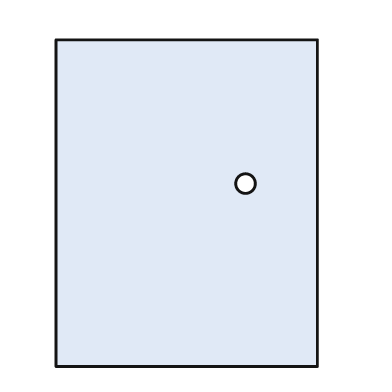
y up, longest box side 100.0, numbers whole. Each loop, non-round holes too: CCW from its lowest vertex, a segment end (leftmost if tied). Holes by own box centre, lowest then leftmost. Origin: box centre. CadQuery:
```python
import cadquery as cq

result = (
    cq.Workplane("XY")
    .moveTo(-40.0, -50.0)
    .lineTo(40.0, -50.0)
    .lineTo(40.0, 50.0)
    .lineTo(-40.0, 50.0)
    .close()
    .moveTo(18.0, 6.0)
    .circle(3.0)
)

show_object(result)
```